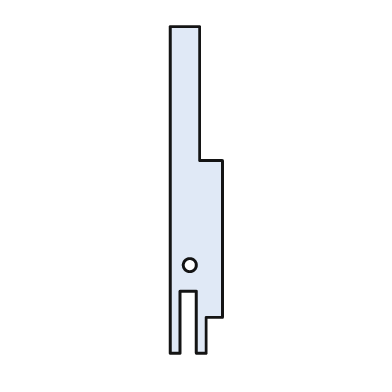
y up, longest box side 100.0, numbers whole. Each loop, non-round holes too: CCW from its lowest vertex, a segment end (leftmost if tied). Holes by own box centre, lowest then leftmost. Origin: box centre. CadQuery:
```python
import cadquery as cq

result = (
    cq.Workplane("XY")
    .moveTo(-8.0, -50.0)
    .lineTo(-5.0, -50.0)
    .lineTo(-5.0, -31.0)
    .lineTo(0.0, -31.0)
    .lineTo(0.0, -50.0)
    .lineTo(3.0, -50.0)
    .lineTo(3.0, -39.0)
    .lineTo(8.0, -39.0)
    .lineTo(8.0, 9.0)
    .lineTo(1.0, 9.0)
    .lineTo(1.0, 50.0)
    .lineTo(-8.0, 50.0)
    .close()
    .moveTo(-2.0, -23.0)
    .circle(2.0)
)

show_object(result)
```